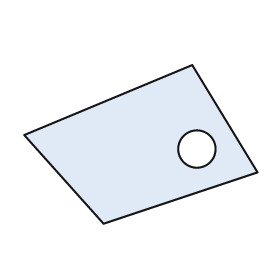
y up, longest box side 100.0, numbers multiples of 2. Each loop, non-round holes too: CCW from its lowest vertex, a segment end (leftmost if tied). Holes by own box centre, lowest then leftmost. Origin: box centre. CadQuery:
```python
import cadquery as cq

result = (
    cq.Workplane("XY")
    .moveTo(-16.0, -34.0)
    .lineTo(50.0, -12.0)
    .lineTo(22.0, 34.0)
    .lineTo(-50.0, 4.0)
    .close()
    .moveTo(24.0, -2.0)
    .circle(8.0)
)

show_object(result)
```